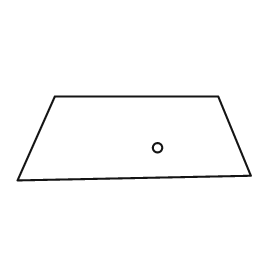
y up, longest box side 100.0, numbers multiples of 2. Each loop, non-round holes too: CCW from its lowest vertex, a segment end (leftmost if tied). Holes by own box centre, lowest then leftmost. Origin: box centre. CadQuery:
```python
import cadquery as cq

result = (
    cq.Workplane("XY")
    .moveTo(-50.0, -18.0)
    .lineTo(50.0, -16.0)
    .lineTo(36.0, 18.0)
    .lineTo(-34.0, 18.0)
    .close()
    .moveTo(10.0, -4.0)
    .circle(2.0)
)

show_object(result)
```